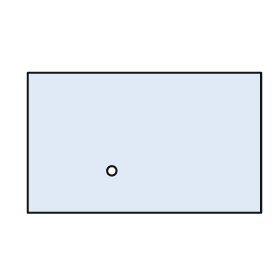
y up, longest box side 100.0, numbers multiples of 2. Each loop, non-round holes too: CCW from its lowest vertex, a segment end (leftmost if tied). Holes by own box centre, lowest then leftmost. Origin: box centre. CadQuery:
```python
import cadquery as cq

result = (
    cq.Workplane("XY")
    .moveTo(-50.0, -30.0)
    .lineTo(50.0, -30.0)
    .lineTo(50.0, 30.0)
    .lineTo(-50.0, 30.0)
    .close()
    .moveTo(-14.0, -12.0)
    .circle(2.0)
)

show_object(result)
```